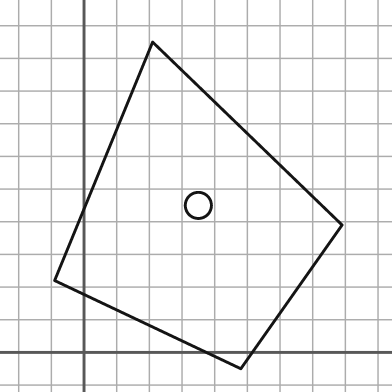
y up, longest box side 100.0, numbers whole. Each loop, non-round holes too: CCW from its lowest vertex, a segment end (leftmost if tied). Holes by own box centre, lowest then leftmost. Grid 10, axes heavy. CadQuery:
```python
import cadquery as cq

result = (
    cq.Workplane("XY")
    .moveTo(48.0, -5.0)
    .lineTo(79.0, 39.0)
    .lineTo(21.0, 95.0)
    .lineTo(-9.0, 22.0)
    .close()
    .moveTo(35.0, 45.0)
    .circle(4.0)
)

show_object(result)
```